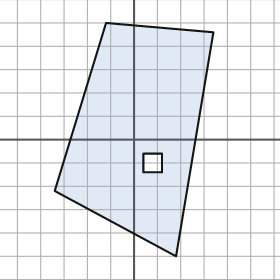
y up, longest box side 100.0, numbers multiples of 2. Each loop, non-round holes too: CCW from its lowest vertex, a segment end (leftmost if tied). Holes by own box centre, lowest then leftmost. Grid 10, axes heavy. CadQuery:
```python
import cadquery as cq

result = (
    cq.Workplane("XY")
    .moveTo(18.0, -50.0)
    .lineTo(34.0, 46.0)
    .lineTo(-12.0, 50.0)
    .lineTo(-34.0, -22.0)
    .close()
    .moveTo(4.0, -14.0)
    .lineTo(12.0, -14.0)
    .lineTo(12.0, -6.0)
    .lineTo(4.0, -6.0)
    .close()
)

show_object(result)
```